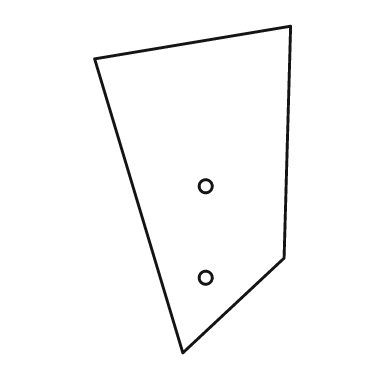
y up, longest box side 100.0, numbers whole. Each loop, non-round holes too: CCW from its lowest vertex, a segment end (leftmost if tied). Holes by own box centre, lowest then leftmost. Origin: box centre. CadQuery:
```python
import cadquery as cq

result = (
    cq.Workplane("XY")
    .moveTo(-3.0, -50.0)
    .lineTo(28.0, -21.0)
    .lineTo(30.0, 50.0)
    .lineTo(-30.0, 40.0)
    .close()
    .moveTo(4.0, -27.0)
    .circle(2.0)
    .moveTo(4.0, 1.0)
    .circle(2.0)
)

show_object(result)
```